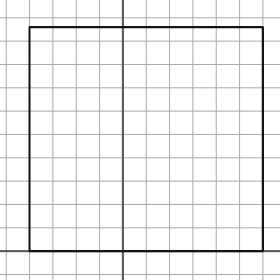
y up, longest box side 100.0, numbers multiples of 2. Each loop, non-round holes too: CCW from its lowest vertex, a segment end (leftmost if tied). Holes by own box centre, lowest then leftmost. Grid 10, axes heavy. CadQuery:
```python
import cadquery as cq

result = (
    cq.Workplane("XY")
    .moveTo(-40.0, 0.0)
    .lineTo(60.0, 0.0)
    .lineTo(60.0, 96.0)
    .lineTo(-40.0, 96.0)
    .close()
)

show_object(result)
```